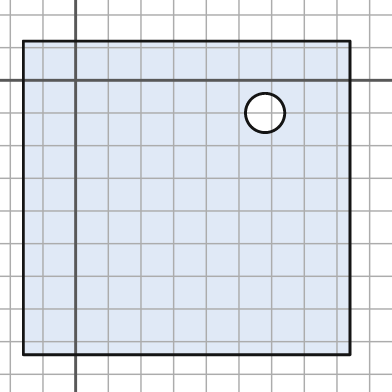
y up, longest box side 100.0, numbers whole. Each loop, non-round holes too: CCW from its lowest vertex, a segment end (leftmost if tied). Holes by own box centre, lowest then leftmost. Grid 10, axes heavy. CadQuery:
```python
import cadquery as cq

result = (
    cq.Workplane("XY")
    .moveTo(-16.0, -84.0)
    .lineTo(84.0, -84.0)
    .lineTo(84.0, 12.0)
    .lineTo(-16.0, 12.0)
    .close()
    .moveTo(58.0, -10.0)
    .circle(6.0)
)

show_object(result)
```